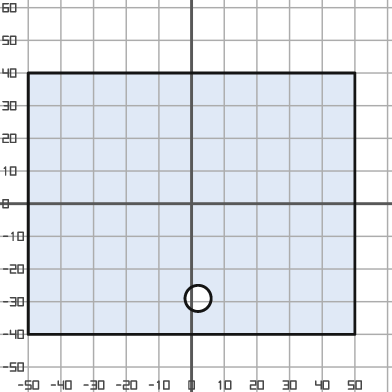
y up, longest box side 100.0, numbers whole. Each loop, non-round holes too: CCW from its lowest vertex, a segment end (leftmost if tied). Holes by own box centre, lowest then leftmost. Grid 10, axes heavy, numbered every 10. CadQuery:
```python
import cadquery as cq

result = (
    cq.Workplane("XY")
    .moveTo(-50.0, -40.0)
    .lineTo(50.0, -40.0)
    .lineTo(50.0, 40.0)
    .lineTo(-50.0, 40.0)
    .close()
    .moveTo(2.0, -29.0)
    .circle(4.0)
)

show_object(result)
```